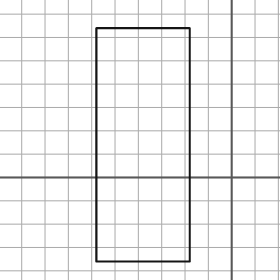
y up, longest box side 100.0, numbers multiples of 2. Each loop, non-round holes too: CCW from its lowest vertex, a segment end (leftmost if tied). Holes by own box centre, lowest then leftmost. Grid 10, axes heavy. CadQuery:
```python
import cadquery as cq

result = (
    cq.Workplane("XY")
    .moveTo(-58.0, -36.0)
    .lineTo(-18.0, -36.0)
    .lineTo(-18.0, 64.0)
    .lineTo(-58.0, 64.0)
    .close()
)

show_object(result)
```